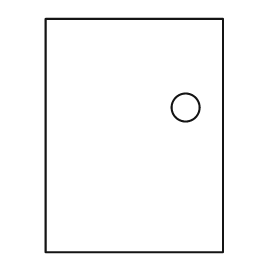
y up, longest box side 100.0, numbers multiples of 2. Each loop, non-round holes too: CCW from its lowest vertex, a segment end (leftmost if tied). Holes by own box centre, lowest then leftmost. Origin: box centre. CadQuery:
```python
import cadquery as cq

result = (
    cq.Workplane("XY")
    .moveTo(-38.0, -50.0)
    .lineTo(38.0, -50.0)
    .lineTo(38.0, 50.0)
    .lineTo(-38.0, 50.0)
    .close()
    .moveTo(22.0, 12.0)
    .circle(6.0)
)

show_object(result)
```